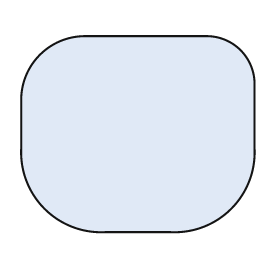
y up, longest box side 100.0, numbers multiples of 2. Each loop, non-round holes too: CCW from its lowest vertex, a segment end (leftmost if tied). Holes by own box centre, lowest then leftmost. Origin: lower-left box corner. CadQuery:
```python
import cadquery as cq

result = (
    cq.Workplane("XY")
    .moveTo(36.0, 0.0)
    .lineTo(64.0, 0.0)
    .threePointArc((90.0, 10.0), (100.0, 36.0))
    .lineTo(100.0, 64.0)
    .threePointArc((94.0, 78.0), (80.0, 84.0))
    .lineTo(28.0, 84.0)
    .threePointArc((8.0, 76.0), (0.0, 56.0))
    .lineTo(0.0, 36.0)
    .threePointArc((10.0, 10.0), (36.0, 0.0))
    .close()
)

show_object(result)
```